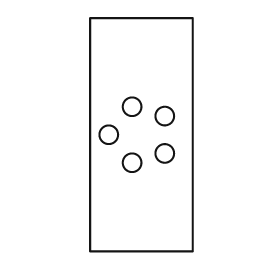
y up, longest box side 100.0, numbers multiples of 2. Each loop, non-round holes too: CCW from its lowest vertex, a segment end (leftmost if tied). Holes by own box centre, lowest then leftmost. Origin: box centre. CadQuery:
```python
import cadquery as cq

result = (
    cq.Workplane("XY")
    .moveTo(-22.0, -50.0)
    .lineTo(22.0, -50.0)
    .lineTo(22.0, 50.0)
    .lineTo(-22.0, 50.0)
    .close()
    .moveTo(-4.0, -12.0)
    .circle(4.0)
    .moveTo(10.0, -8.0)
    .circle(4.0)
    .moveTo(-14.0, 0.0)
    .circle(4.0)
    .moveTo(10.0, 8.0)
    .circle(4.0)
    .moveTo(-4.0, 12.0)
    .circle(4.0)
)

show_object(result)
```